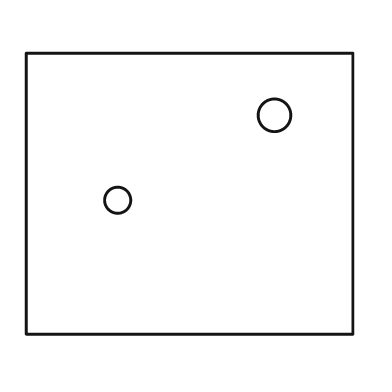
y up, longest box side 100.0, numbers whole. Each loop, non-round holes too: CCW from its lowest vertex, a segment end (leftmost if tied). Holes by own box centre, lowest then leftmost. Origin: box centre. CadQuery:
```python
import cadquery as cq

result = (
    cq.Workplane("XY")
    .moveTo(-50.0, -43.0)
    .lineTo(50.0, -43.0)
    .lineTo(50.0, 43.0)
    .lineTo(-50.0, 43.0)
    .close()
    .moveTo(-22.0, -2.0)
    .circle(4.0)
    .moveTo(26.0, 24.0)
    .circle(5.0)
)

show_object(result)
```